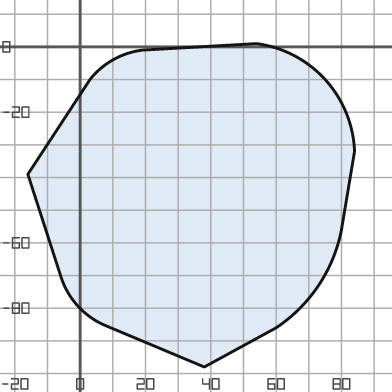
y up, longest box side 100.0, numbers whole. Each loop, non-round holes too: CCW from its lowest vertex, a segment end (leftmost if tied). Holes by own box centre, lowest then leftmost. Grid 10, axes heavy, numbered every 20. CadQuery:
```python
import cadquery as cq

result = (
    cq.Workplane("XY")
    .moveTo(38.0, -98.0)
    .lineTo(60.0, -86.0)
    .threePointArc((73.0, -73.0), (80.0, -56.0))
    .lineTo(84.0, -32.0)
    .threePointArc((75.0, -10.0), (54.0, 1.0))
    .lineTo(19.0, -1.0)
    .threePointArc((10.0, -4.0), (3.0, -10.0))
    .lineTo(-16.0, -39.0)
    .lineTo(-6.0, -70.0)
    .threePointArc((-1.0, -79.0), (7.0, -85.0))
    .close()
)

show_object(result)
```